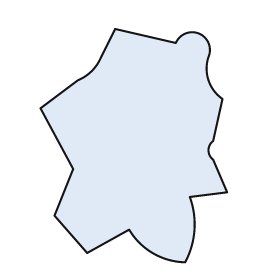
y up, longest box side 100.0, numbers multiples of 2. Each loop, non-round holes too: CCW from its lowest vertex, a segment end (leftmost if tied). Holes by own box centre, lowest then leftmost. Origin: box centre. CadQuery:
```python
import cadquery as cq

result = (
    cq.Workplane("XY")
    .moveTo(22.0, -50.0)
    .threePointArc((26.0, -36.0), (24.0, -22.0))
    .lineTo(40.0, -20.0)
    .lineTo(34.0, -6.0)
    .threePointArc((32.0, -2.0), (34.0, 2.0))
    .lineTo(38.0, 20.0)
    .threePointArc((32.0, 28.0), (32.0, 38.0))
    .threePointArc((28.0, 48.0), (18.0, 44.0))
    .lineTo(-8.0, 50.0)
    .lineTo(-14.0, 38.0)
    .threePointArc((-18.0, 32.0), (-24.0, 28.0))
    .lineTo(-40.0, 16.0)
    .lineTo(-26.0, -10.0)
    .lineTo(-34.0, -30.0)
    .lineTo(-20.0, -46.0)
    .lineTo(-2.0, -36.0)
    .threePointArc((8.0, -46.0), (22.0, -50.0))
    .close()
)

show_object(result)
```